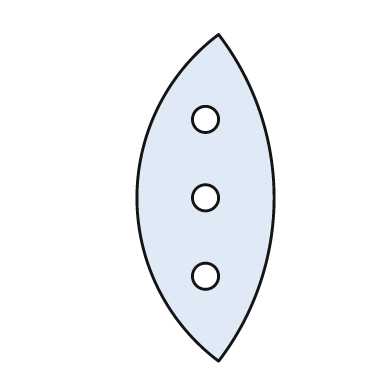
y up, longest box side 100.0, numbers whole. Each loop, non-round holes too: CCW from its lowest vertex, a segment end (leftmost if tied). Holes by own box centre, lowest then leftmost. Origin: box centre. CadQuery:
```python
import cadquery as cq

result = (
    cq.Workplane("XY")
    .moveTo(4.0, -50.0)
    .threePointArc((21.0, 0.0), (4.0, 50.0))
    .threePointArc((-21.0, 0.0), (4.0, -50.0))
    .close()
    .moveTo(0.0, -24.0)
    .circle(4.0)
    .moveTo(0.0, 0.0)
    .circle(4.0)
    .moveTo(0.0, 24.0)
    .circle(4.0)
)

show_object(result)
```